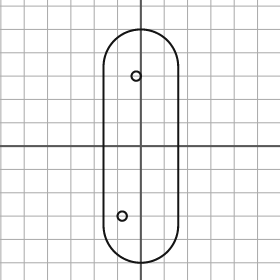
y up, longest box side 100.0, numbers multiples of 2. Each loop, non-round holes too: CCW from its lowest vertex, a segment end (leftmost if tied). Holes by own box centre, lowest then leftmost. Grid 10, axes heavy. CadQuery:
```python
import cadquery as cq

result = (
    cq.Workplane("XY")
    .moveTo(-16.0, -34.0)
    .threePointArc((0.0, -50.0), (16.0, -34.0))
    .lineTo(16.0, 34.0)
    .threePointArc((0.0, 50.0), (-16.0, 34.0))
    .close()
    .moveTo(-8.0, -30.0)
    .circle(2.0)
    .moveTo(-2.0, 30.0)
    .circle(2.0)
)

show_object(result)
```